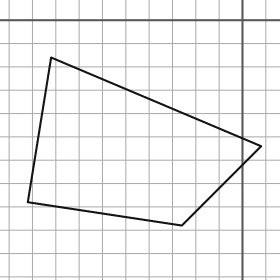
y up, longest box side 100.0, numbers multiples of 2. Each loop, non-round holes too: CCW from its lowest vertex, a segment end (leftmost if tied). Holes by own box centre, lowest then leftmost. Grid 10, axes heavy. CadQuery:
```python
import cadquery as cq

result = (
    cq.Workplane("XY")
    .moveTo(-26.0, -88.0)
    .lineTo(8.0, -54.0)
    .lineTo(-82.0, -16.0)
    .lineTo(-92.0, -78.0)
    .close()
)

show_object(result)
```